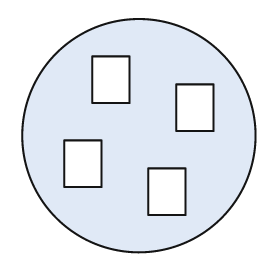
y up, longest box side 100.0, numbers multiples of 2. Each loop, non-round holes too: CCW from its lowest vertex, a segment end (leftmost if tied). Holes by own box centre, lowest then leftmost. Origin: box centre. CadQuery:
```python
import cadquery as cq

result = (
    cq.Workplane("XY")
    .moveTo(0.0, 0.0)
    .circle(50.0)
    .moveTo(4.0, -34.0)
    .lineTo(20.0, -34.0)
    .lineTo(20.0, -14.0)
    .lineTo(4.0, -14.0)
    .close()
    .moveTo(-32.0, -22.0)
    .lineTo(-16.0, -22.0)
    .lineTo(-16.0, -2.0)
    .lineTo(-32.0, -2.0)
    .close()
    .moveTo(16.0, 2.0)
    .lineTo(32.0, 2.0)
    .lineTo(32.0, 22.0)
    .lineTo(16.0, 22.0)
    .close()
    .moveTo(-20.0, 14.0)
    .lineTo(-4.0, 14.0)
    .lineTo(-4.0, 34.0)
    .lineTo(-20.0, 34.0)
    .close()
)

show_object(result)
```